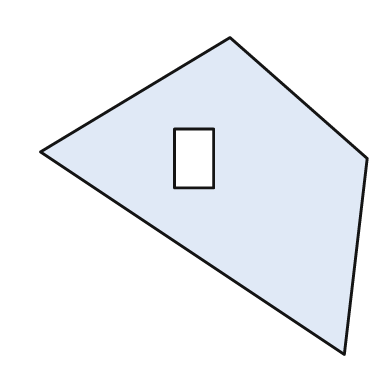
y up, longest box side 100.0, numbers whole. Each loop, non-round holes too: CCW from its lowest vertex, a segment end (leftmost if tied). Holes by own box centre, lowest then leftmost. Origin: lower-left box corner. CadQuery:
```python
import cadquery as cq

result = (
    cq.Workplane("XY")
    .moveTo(93.0, 0.0)
    .lineTo(100.0, 60.0)
    .lineTo(58.0, 97.0)
    .lineTo(0.0, 62.0)
    .close()
    .moveTo(41.0, 51.0)
    .lineTo(53.0, 51.0)
    .lineTo(53.0, 69.0)
    .lineTo(41.0, 69.0)
    .close()
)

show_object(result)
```